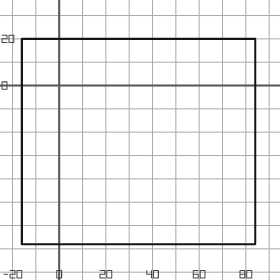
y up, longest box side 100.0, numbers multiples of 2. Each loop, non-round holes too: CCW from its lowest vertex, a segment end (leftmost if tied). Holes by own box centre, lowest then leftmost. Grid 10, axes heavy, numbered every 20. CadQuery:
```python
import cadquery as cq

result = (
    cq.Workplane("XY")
    .moveTo(-16.0, -68.0)
    .lineTo(84.0, -68.0)
    .lineTo(84.0, 20.0)
    .lineTo(-16.0, 20.0)
    .close()
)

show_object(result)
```